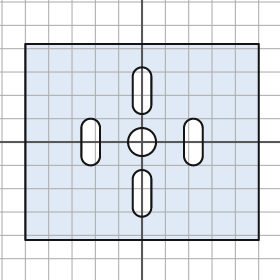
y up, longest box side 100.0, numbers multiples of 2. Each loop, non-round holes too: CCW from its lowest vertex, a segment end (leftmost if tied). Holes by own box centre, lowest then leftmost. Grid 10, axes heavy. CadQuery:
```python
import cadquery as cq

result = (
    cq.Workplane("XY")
    .moveTo(-50.0, -42.0)
    .lineTo(50.0, -42.0)
    .lineTo(50.0, 42.0)
    .lineTo(-50.0, 42.0)
    .close()
    .moveTo(-4.0, -28.0)
    .threePointArc((0.0, -32.0), (4.0, -28.0))
    .lineTo(4.0, -16.0)
    .threePointArc((0.0, -12.0), (-4.0, -16.0))
    .close()
    .moveTo(-26.0, -6.0)
    .threePointArc((-22.0, -10.0), (-18.0, -6.0))
    .lineTo(-18.0, 6.0)
    .threePointArc((-22.0, 10.0), (-26.0, 6.0))
    .close()
    .moveTo(0.0, 0.0)
    .circle(6.0)
    .moveTo(18.0, -6.0)
    .threePointArc((22.0, -10.0), (26.0, -6.0))
    .lineTo(26.0, 6.0)
    .threePointArc((22.0, 10.0), (18.0, 6.0))
    .close()
    .moveTo(-4.0, 16.0)
    .threePointArc((0.0, 12.0), (4.0, 16.0))
    .lineTo(4.0, 28.0)
    .threePointArc((0.0, 32.0), (-4.0, 28.0))
    .close()
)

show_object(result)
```